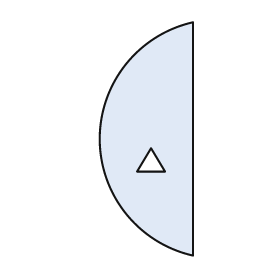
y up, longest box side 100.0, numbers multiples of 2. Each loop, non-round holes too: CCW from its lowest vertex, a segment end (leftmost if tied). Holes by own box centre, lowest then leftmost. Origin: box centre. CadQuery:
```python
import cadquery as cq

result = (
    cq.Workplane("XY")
    .moveTo(20.0, -50.0)
    .lineTo(20.0, 50.0)
    .threePointArc((-20.0, 0.0), (20.0, -50.0))
    .close()
    .moveTo(-4.0, -14.0)
    .lineTo(8.0, -14.0)
    .lineTo(2.0, -4.0)
    .close()
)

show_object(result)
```